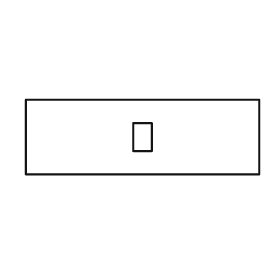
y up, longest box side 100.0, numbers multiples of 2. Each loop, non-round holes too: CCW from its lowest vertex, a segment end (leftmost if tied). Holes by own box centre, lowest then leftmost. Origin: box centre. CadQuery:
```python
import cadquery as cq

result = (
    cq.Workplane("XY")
    .moveTo(-50.0, -16.0)
    .lineTo(50.0, -16.0)
    .lineTo(50.0, 16.0)
    .lineTo(-50.0, 16.0)
    .close()
    .moveTo(-4.0, -6.0)
    .lineTo(4.0, -6.0)
    .lineTo(4.0, 6.0)
    .lineTo(-4.0, 6.0)
    .close()
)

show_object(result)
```